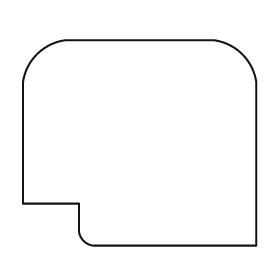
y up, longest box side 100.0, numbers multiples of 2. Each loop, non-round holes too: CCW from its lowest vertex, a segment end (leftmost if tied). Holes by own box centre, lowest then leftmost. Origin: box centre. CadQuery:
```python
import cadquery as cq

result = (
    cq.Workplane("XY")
    .moveTo(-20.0, -44.0)
    .lineTo(50.0, -44.0)
    .lineTo(50.0, 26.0)
    .threePointArc((44.0, 38.0), (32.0, 44.0))
    .lineTo(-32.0, 44.0)
    .threePointArc((-44.0, 38.0), (-50.0, 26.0))
    .lineTo(-50.0, -26.0)
    .lineTo(-26.0, -26.0)
    .lineTo(-26.0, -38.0)
    .threePointArc((-24.0, -42.0), (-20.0, -44.0))
    .close()
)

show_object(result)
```